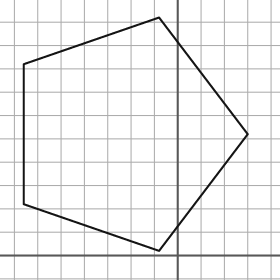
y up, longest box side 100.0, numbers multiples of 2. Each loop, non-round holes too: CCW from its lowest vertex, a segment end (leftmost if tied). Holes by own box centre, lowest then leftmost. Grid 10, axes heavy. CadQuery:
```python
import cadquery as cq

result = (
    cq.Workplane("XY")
    .moveTo(-8.0, 2.0)
    .lineTo(30.0, 52.0)
    .lineTo(-8.0, 102.0)
    .lineTo(-66.0, 82.0)
    .lineTo(-66.0, 22.0)
    .close()
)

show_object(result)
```